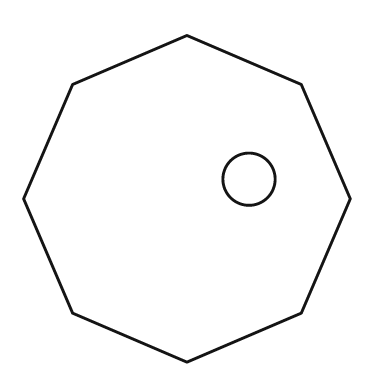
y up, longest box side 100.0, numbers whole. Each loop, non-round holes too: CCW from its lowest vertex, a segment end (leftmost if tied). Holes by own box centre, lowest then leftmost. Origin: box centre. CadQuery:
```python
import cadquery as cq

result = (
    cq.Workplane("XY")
    .moveTo(0.0, -50.0)
    .lineTo(35.0, -35.0)
    .lineTo(50.0, 0.0)
    .lineTo(35.0, 35.0)
    .lineTo(0.0, 50.0)
    .lineTo(-35.0, 35.0)
    .lineTo(-50.0, 0.0)
    .lineTo(-35.0, -35.0)
    .close()
    .moveTo(19.0, 6.0)
    .circle(8.0)
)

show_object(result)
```